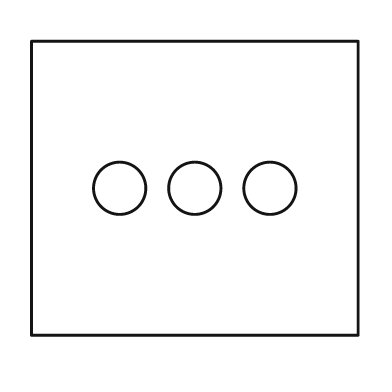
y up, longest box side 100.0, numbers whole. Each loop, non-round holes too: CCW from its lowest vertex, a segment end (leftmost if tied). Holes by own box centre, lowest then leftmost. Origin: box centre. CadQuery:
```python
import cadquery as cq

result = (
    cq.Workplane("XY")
    .moveTo(-50.0, -45.0)
    .lineTo(50.0, -45.0)
    .lineTo(50.0, 45.0)
    .lineTo(-50.0, 45.0)
    .close()
    .moveTo(-23.0, 0.0)
    .circle(8.0)
    .moveTo(0.0, 0.0)
    .circle(8.0)
    .moveTo(23.0, 0.0)
    .circle(8.0)
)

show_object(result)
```